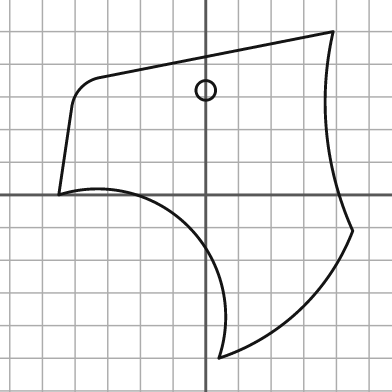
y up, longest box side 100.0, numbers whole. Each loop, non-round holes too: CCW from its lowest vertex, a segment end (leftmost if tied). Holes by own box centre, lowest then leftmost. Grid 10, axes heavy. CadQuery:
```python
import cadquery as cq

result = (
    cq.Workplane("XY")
    .moveTo(4.0, -50.0)
    .threePointArc((29.0, -35.0), (45.0, -11.0))
    .threePointArc((37.0, 19.0), (39.0, 50.0))
    .lineTo(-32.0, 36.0)
    .threePointArc((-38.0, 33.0), (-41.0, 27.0))
    .lineTo(-45.0, 0.0)
    .threePointArc((-5.0, -10.0), (4.0, -50.0))
    .close()
    .moveTo(0.0, 32.0)
    .circle(3.0)
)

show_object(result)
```